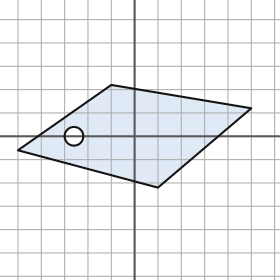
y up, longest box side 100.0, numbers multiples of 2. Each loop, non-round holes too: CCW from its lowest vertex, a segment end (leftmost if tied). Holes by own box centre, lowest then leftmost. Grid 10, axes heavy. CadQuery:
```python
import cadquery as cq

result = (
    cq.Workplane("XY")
    .moveTo(10.0, -22.0)
    .lineTo(50.0, 12.0)
    .lineTo(-10.0, 22.0)
    .lineTo(-50.0, -6.0)
    .close()
    .moveTo(-26.0, 0.0)
    .circle(4.0)
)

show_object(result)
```